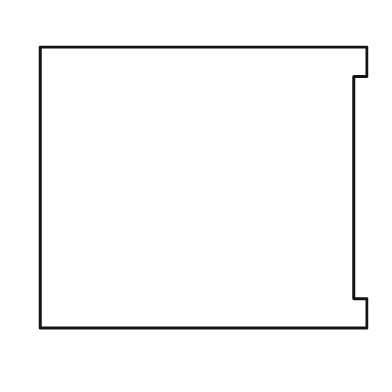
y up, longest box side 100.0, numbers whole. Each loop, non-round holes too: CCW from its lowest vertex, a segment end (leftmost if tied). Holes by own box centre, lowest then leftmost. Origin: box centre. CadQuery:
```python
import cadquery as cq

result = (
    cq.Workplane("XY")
    .moveTo(-50.0, -43.0)
    .lineTo(50.0, -43.0)
    .lineTo(50.0, -34.0)
    .lineTo(46.0, -34.0)
    .lineTo(46.0, 34.0)
    .lineTo(50.0, 34.0)
    .lineTo(50.0, 43.0)
    .lineTo(-50.0, 43.0)
    .close()
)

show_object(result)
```